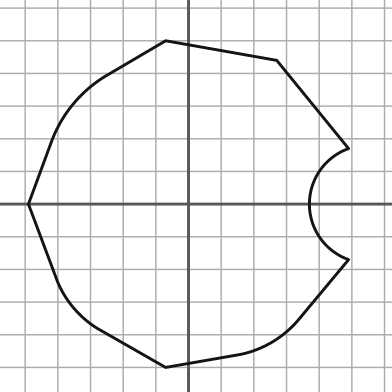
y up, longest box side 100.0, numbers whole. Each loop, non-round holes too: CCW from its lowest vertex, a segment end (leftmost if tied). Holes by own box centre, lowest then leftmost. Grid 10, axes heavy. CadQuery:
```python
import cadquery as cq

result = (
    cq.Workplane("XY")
    .moveTo(-7.0, -50.0)
    .lineTo(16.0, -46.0)
    .threePointArc((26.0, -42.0), (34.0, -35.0))
    .lineTo(49.0, -17.0)
    .threePointArc((37.0, 0.0), (49.0, 17.0))
    .lineTo(27.0, 44.0)
    .lineTo(-7.0, 50.0)
    .lineTo(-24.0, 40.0)
    .threePointArc((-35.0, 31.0), (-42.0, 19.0))
    .lineTo(-49.0, 0.0)
    .lineTo(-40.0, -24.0)
    .threePointArc((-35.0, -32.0), (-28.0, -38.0))
    .close()
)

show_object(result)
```